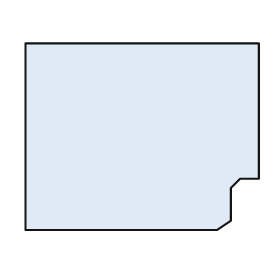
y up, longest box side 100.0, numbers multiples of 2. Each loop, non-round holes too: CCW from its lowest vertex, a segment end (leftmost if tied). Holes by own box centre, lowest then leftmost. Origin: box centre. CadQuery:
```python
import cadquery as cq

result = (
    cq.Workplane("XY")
    .moveTo(-50.0, -40.0)
    .lineTo(32.0, -40.0)
    .lineTo(38.0, -36.0)
    .lineTo(38.0, -22.0)
    .lineTo(42.0, -18.0)
    .lineTo(50.0, -18.0)
    .lineTo(50.0, 40.0)
    .lineTo(-50.0, 40.0)
    .close()
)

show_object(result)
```